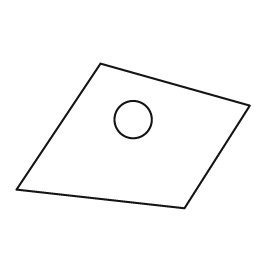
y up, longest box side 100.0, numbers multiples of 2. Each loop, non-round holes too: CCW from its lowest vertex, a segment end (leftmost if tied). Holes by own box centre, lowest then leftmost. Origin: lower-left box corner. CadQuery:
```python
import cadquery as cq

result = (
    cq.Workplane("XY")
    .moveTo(72.0, 0.0)
    .lineTo(100.0, 44.0)
    .lineTo(36.0, 62.0)
    .lineTo(0.0, 8.0)
    .close()
    .moveTo(50.0, 38.0)
    .circle(8.0)
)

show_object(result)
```